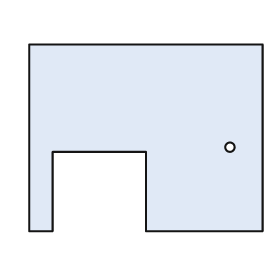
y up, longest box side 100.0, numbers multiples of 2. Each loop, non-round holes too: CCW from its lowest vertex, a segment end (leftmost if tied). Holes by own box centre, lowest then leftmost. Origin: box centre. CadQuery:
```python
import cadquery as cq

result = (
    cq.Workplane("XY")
    .moveTo(-50.0, -40.0)
    .lineTo(-40.0, -40.0)
    .lineTo(-40.0, -6.0)
    .lineTo(0.0, -6.0)
    .lineTo(0.0, -40.0)
    .lineTo(50.0, -40.0)
    .lineTo(50.0, 40.0)
    .lineTo(-50.0, 40.0)
    .close()
    .moveTo(36.0, -4.0)
    .circle(2.0)
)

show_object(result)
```